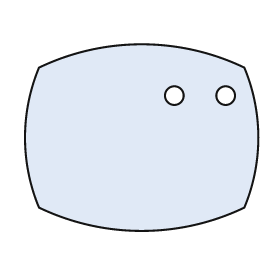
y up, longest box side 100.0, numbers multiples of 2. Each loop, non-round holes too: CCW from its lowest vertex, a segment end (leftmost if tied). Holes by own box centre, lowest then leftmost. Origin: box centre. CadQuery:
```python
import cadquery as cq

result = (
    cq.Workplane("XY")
    .moveTo(-44.0, -30.0)
    .threePointArc((0.0, -40.0), (44.0, -30.0))
    .threePointArc((50.0, 0.0), (44.0, 30.0))
    .threePointArc((0.0, 40.0), (-44.0, 30.0))
    .threePointArc((-50.0, 0.0), (-44.0, -30.0))
    .close()
    .moveTo(14.0, 18.0)
    .circle(4.0)
    .moveTo(36.0, 18.0)
    .circle(4.0)
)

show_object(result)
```